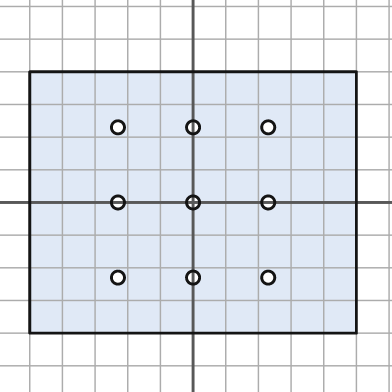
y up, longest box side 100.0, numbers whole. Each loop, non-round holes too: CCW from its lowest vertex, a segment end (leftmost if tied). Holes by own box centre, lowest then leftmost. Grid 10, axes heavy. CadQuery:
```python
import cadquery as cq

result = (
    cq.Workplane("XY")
    .moveTo(-50.0, -40.0)
    .lineTo(50.0, -40.0)
    .lineTo(50.0, 40.0)
    .lineTo(-50.0, 40.0)
    .close()
    .moveTo(-23.0, -23.0)
    .circle(2.0)
    .moveTo(0.0, -23.0)
    .circle(2.0)
    .moveTo(23.0, -23.0)
    .circle(2.0)
    .moveTo(-23.0, 0.0)
    .circle(2.0)
    .moveTo(0.0, 0.0)
    .circle(2.0)
    .moveTo(23.0, 0.0)
    .circle(2.0)
    .moveTo(-23.0, 23.0)
    .circle(2.0)
    .moveTo(0.0, 23.0)
    .circle(2.0)
    .moveTo(23.0, 23.0)
    .circle(2.0)
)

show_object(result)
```